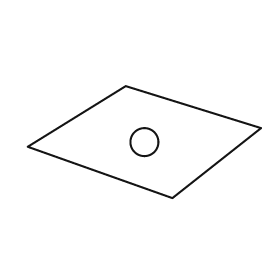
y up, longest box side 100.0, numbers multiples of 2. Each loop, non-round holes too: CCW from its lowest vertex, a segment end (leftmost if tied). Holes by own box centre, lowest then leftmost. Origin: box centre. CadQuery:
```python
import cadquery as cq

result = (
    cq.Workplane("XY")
    .moveTo(12.0, -24.0)
    .lineTo(50.0, 6.0)
    .lineTo(-8.0, 24.0)
    .lineTo(-50.0, -2.0)
    .close()
    .moveTo(0.0, 0.0)
    .circle(6.0)
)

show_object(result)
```